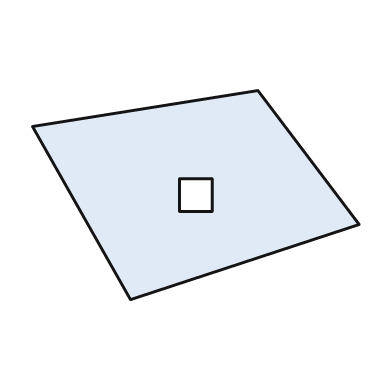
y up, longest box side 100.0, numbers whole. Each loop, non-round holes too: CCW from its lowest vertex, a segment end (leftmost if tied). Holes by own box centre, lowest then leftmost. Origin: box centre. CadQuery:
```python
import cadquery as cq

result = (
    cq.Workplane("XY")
    .moveTo(-20.0, -32.0)
    .lineTo(50.0, -9.0)
    .lineTo(19.0, 32.0)
    .lineTo(-50.0, 21.0)
    .close()
    .moveTo(-5.0, -5.0)
    .lineTo(5.0, -5.0)
    .lineTo(5.0, 5.0)
    .lineTo(-5.0, 5.0)
    .close()
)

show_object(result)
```